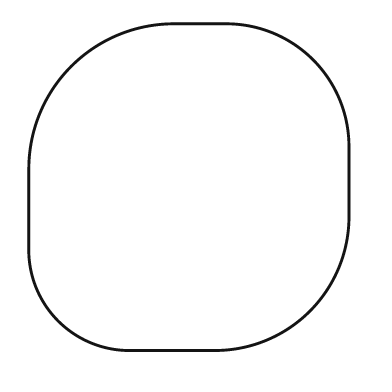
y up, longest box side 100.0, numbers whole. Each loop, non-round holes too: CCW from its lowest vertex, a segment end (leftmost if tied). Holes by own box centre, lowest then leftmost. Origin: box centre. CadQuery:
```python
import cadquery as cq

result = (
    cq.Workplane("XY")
    .moveTo(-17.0, -50.0)
    .lineTo(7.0, -50.0)
    .threePointArc((37.0, -38.0), (49.0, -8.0))
    .lineTo(49.0, 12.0)
    .threePointArc((38.0, 39.0), (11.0, 50.0))
    .lineTo(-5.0, 50.0)
    .threePointArc((-36.0, 37.0), (-49.0, 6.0))
    .lineTo(-49.0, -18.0)
    .threePointArc((-40.0, -41.0), (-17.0, -50.0))
    .close()
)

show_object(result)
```